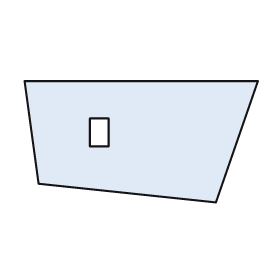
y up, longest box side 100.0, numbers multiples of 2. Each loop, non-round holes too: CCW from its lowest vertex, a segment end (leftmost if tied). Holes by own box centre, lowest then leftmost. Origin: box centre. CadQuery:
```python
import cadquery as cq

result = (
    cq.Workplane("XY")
    .moveTo(32.0, -26.0)
    .lineTo(50.0, 26.0)
    .lineTo(-50.0, 26.0)
    .lineTo(-44.0, -18.0)
    .close()
    .moveTo(-22.0, -2.0)
    .lineTo(-14.0, -2.0)
    .lineTo(-14.0, 10.0)
    .lineTo(-22.0, 10.0)
    .close()
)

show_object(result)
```